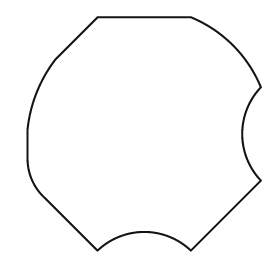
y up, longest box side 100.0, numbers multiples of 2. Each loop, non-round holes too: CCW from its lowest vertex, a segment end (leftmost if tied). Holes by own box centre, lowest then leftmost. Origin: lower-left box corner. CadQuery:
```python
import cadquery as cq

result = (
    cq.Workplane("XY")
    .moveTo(30.0, 0.0)
    .threePointArc((50.0, 8.0), (70.0, 0.0))
    .lineTo(100.0, 30.0)
    .threePointArc((92.0, 50.0), (100.0, 70.0))
    .threePointArc((88.0, 88.0), (70.0, 100.0))
    .lineTo(30.0, 100.0)
    .lineTo(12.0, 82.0)
    .threePointArc((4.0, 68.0), (0.0, 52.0))
    .lineTo(0.0, 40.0)
    .threePointArc((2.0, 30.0), (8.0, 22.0))
    .close()
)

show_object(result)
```